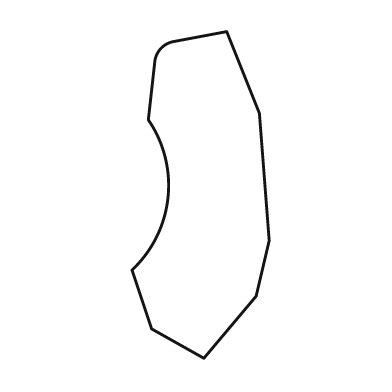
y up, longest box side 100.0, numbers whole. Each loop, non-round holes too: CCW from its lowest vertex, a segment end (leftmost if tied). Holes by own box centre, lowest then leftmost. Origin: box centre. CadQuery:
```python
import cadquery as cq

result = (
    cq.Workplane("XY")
    .moveTo(1.0, -50.0)
    .lineTo(17.0, -31.0)
    .lineTo(21.0, -14.0)
    .lineTo(18.0, 25.0)
    .lineTo(8.0, 50.0)
    .lineTo(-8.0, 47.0)
    .threePointArc((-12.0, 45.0), (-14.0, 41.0))
    .lineTo(-16.0, 23.0)
    .threePointArc((-10.0, -1.0), (-21.0, -23.0))
    .lineTo(-15.0, -41.0)
    .close()
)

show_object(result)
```